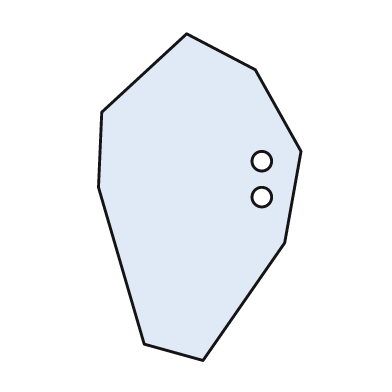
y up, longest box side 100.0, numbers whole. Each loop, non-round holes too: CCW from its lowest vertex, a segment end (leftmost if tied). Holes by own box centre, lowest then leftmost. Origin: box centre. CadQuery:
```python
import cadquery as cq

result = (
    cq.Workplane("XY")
    .moveTo(1.0, -50.0)
    .lineTo(26.0, -14.0)
    .lineTo(31.0, 14.0)
    .lineTo(17.0, 39.0)
    .lineTo(-4.0, 50.0)
    .lineTo(-30.0, 26.0)
    .lineTo(-31.0, 3.0)
    .lineTo(-17.0, -45.0)
    .close()
    .moveTo(19.0, 0.0)
    .circle(3.0)
    .moveTo(19.0, 11.0)
    .circle(3.0)
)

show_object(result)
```